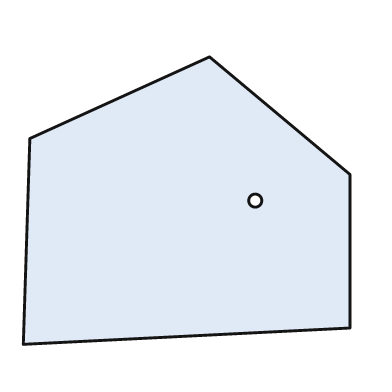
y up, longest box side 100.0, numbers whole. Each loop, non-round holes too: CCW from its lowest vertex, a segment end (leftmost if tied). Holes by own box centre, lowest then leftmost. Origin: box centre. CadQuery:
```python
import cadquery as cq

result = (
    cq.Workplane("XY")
    .moveTo(-50.0, -44.0)
    .lineTo(50.0, -39.0)
    .lineTo(50.0, 8.0)
    .lineTo(7.0, 44.0)
    .lineTo(-48.0, 19.0)
    .close()
    .moveTo(21.0, 0.0)
    .circle(2.0)
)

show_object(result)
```